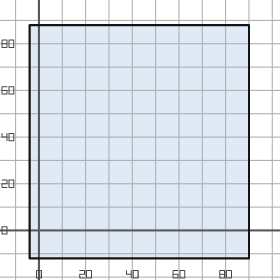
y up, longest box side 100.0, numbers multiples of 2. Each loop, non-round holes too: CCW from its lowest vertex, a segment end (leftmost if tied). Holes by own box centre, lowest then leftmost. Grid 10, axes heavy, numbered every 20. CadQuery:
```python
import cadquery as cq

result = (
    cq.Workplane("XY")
    .moveTo(-4.0, -12.0)
    .lineTo(90.0, -12.0)
    .lineTo(90.0, 88.0)
    .lineTo(-4.0, 88.0)
    .close()
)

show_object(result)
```